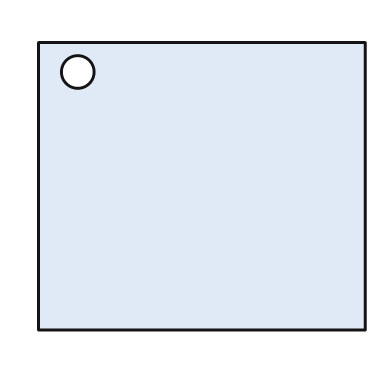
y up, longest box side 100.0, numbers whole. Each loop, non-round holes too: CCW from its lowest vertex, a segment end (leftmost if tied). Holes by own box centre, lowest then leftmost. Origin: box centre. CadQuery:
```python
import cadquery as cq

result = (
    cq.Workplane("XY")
    .moveTo(-50.0, -44.0)
    .lineTo(50.0, -44.0)
    .lineTo(50.0, 44.0)
    .lineTo(-50.0, 44.0)
    .close()
    .moveTo(-38.0, 35.0)
    .circle(5.0)
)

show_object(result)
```